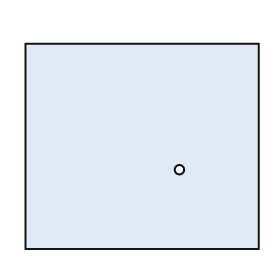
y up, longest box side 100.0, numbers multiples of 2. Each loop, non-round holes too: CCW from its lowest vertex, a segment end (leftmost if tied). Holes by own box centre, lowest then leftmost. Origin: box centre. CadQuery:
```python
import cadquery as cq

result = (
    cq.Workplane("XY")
    .moveTo(-50.0, -44.0)
    .lineTo(50.0, -44.0)
    .lineTo(50.0, 44.0)
    .lineTo(-50.0, 44.0)
    .close()
    .moveTo(16.0, -10.0)
    .circle(2.0)
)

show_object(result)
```